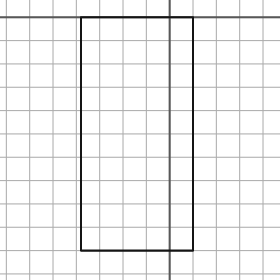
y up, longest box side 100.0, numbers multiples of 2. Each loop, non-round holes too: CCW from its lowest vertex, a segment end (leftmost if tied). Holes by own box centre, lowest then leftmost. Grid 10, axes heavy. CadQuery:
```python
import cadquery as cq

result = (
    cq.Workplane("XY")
    .moveTo(-38.0, -100.0)
    .lineTo(10.0, -100.0)
    .lineTo(10.0, 0.0)
    .lineTo(-38.0, 0.0)
    .close()
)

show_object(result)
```